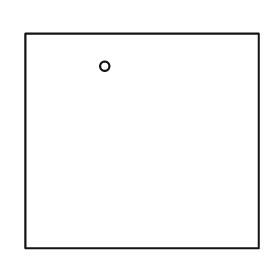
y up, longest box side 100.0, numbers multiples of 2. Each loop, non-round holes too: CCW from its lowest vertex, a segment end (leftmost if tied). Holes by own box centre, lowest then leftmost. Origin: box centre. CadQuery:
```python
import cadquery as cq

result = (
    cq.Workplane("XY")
    .moveTo(-50.0, -46.0)
    .lineTo(50.0, -46.0)
    .lineTo(50.0, 46.0)
    .lineTo(-50.0, 46.0)
    .close()
    .moveTo(-16.0, 32.0)
    .circle(2.0)
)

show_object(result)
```